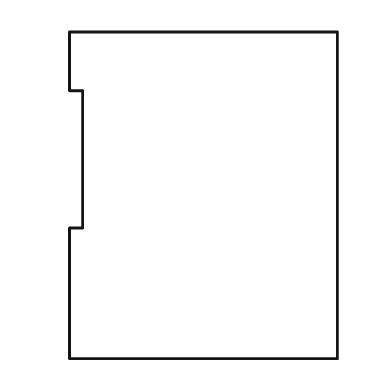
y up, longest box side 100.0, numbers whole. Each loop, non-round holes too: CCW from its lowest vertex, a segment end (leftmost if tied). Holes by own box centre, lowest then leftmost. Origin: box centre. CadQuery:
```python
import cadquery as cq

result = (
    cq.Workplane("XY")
    .moveTo(-41.0, -50.0)
    .lineTo(41.0, -50.0)
    .lineTo(41.0, 50.0)
    .lineTo(-41.0, 50.0)
    .lineTo(-41.0, 32.0)
    .lineTo(-37.0, 32.0)
    .lineTo(-37.0, -10.0)
    .lineTo(-41.0, -10.0)
    .close()
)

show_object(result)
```